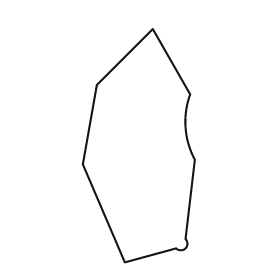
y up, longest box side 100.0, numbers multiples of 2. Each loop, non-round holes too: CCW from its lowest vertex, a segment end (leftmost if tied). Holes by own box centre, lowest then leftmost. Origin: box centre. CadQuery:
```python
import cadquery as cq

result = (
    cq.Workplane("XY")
    .moveTo(-6.0, -50.0)
    .lineTo(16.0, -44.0)
    .threePointArc((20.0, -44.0), (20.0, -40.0))
    .lineTo(24.0, -6.0)
    .threePointArc((20.0, 8.0), (22.0, 22.0))
    .lineTo(6.0, 50.0)
    .lineTo(-18.0, 26.0)
    .lineTo(-24.0, -8.0)
    .close()
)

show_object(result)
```